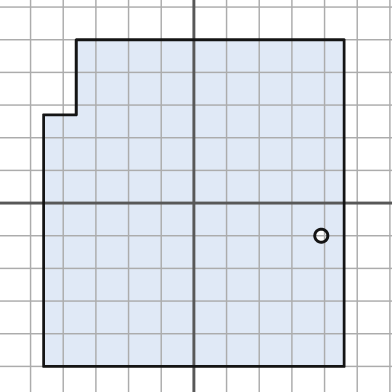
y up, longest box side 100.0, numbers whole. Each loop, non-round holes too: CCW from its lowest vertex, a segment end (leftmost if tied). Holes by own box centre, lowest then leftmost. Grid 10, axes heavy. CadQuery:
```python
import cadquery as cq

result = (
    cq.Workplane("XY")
    .moveTo(-46.0, -50.0)
    .lineTo(46.0, -50.0)
    .lineTo(46.0, 50.0)
    .lineTo(-36.0, 50.0)
    .lineTo(-36.0, 27.0)
    .lineTo(-46.0, 27.0)
    .close()
    .moveTo(39.0, -10.0)
    .circle(2.0)
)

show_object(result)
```